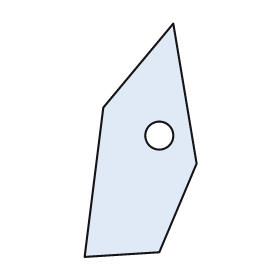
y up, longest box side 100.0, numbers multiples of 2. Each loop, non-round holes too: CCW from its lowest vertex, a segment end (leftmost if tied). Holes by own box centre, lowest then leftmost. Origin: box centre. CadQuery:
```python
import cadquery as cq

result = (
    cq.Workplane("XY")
    .moveTo(-24.0, -50.0)
    .lineTo(8.0, -48.0)
    .lineTo(24.0, -10.0)
    .lineTo(14.0, 50.0)
    .lineTo(-16.0, 14.0)
    .close()
    .moveTo(8.0, 2.0)
    .circle(6.0)
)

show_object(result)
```